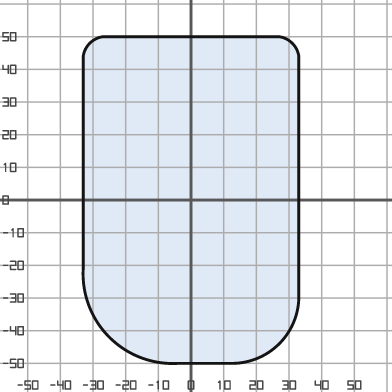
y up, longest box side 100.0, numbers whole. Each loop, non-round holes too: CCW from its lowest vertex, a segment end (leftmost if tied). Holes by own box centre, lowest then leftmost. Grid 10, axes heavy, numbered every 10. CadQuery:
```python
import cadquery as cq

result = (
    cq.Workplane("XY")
    .moveTo(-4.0, -50.0)
    .lineTo(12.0, -50.0)
    .threePointArc((27.0, -44.0), (33.0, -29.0))
    .lineTo(33.0, 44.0)
    .threePointArc((31.0, 48.0), (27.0, 50.0))
    .lineTo(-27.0, 50.0)
    .threePointArc((-31.0, 48.0), (-33.0, 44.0))
    .lineTo(-33.0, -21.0)
    .threePointArc((-25.0, -42.0), (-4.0, -50.0))
    .close()
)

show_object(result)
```